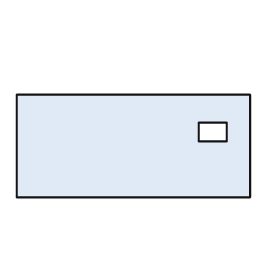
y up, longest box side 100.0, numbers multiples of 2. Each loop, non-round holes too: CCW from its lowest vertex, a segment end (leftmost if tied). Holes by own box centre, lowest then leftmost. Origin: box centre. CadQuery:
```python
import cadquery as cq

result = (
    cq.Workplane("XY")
    .moveTo(-50.0, -22.0)
    .lineTo(50.0, -22.0)
    .lineTo(50.0, 22.0)
    .lineTo(-50.0, 22.0)
    .close()
    .moveTo(28.0, 2.0)
    .lineTo(40.0, 2.0)
    .lineTo(40.0, 10.0)
    .lineTo(28.0, 10.0)
    .close()
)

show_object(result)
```